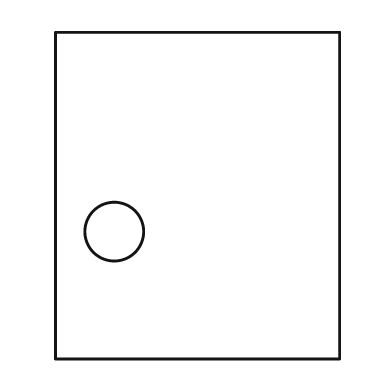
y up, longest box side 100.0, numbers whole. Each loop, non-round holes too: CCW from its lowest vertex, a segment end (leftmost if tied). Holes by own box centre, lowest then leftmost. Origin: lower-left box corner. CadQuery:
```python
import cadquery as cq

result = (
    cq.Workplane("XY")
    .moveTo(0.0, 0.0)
    .lineTo(87.0, 0.0)
    .lineTo(87.0, 100.0)
    .lineTo(0.0, 100.0)
    .close()
    .moveTo(18.0, 39.0)
    .circle(9.0)
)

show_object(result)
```